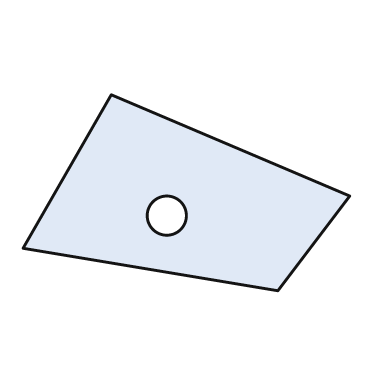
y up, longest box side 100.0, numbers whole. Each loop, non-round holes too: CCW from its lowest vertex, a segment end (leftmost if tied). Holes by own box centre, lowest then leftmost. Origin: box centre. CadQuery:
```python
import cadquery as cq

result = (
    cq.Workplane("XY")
    .moveTo(28.0, -30.0)
    .lineTo(50.0, -1.0)
    .lineTo(-23.0, 30.0)
    .lineTo(-50.0, -17.0)
    .close()
    .moveTo(-6.0, -7.0)
    .circle(6.0)
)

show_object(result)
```